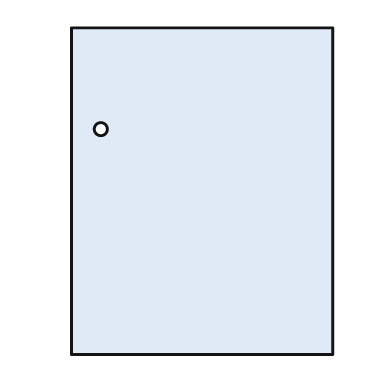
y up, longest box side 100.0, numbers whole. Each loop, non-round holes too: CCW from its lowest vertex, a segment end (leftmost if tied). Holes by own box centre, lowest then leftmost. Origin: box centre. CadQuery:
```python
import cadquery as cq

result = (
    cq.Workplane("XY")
    .moveTo(-40.0, -50.0)
    .lineTo(40.0, -50.0)
    .lineTo(40.0, 50.0)
    .lineTo(-40.0, 50.0)
    .close()
    .moveTo(-31.0, 19.0)
    .circle(2.0)
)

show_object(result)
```